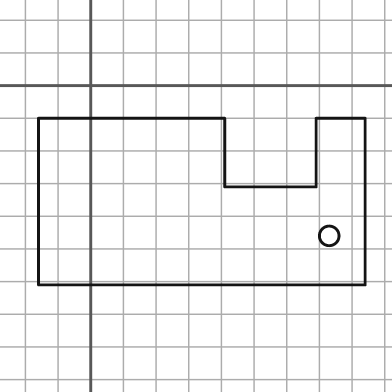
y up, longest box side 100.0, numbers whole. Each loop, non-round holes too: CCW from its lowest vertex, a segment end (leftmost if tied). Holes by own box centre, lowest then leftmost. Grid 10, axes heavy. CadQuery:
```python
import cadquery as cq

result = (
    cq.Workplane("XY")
    .moveTo(-16.0, -61.0)
    .lineTo(84.0, -61.0)
    .lineTo(84.0, -10.0)
    .lineTo(69.0, -10.0)
    .lineTo(69.0, -31.0)
    .lineTo(41.0, -31.0)
    .lineTo(41.0, -10.0)
    .lineTo(-16.0, -10.0)
    .close()
    .moveTo(73.0, -46.0)
    .circle(3.0)
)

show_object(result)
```